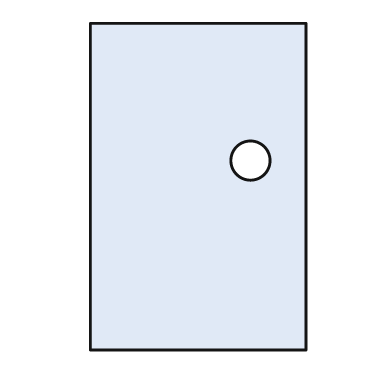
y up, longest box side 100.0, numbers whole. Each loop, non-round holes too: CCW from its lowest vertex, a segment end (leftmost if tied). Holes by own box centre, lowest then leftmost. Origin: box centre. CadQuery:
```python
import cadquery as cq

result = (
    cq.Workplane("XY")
    .moveTo(-33.0, -50.0)
    .lineTo(33.0, -50.0)
    .lineTo(33.0, 50.0)
    .lineTo(-33.0, 50.0)
    .close()
    .moveTo(16.0, 8.0)
    .circle(6.0)
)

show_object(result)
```